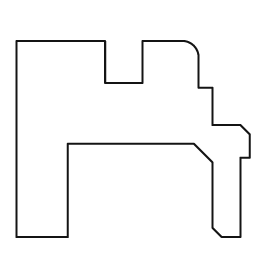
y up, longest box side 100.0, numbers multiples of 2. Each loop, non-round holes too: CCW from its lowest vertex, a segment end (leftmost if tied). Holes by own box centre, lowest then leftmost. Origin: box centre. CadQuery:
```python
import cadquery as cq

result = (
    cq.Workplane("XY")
    .moveTo(-50.0, -42.0)
    .lineTo(-28.0, -42.0)
    .lineTo(-28.0, -2.0)
    .lineTo(26.0, -2.0)
    .lineTo(34.0, -10.0)
    .lineTo(34.0, -38.0)
    .lineTo(38.0, -42.0)
    .lineTo(46.0, -42.0)
    .lineTo(46.0, -8.0)
    .lineTo(50.0, -8.0)
    .lineTo(50.0, 2.0)
    .lineTo(46.0, 6.0)
    .lineTo(34.0, 6.0)
    .lineTo(34.0, 22.0)
    .lineTo(28.0, 22.0)
    .lineTo(28.0, 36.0)
    .threePointArc((26.0, 40.0), (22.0, 42.0))
    .lineTo(4.0, 42.0)
    .lineTo(4.0, 24.0)
    .lineTo(-12.0, 24.0)
    .lineTo(-12.0, 42.0)
    .lineTo(-50.0, 42.0)
    .close()
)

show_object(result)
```